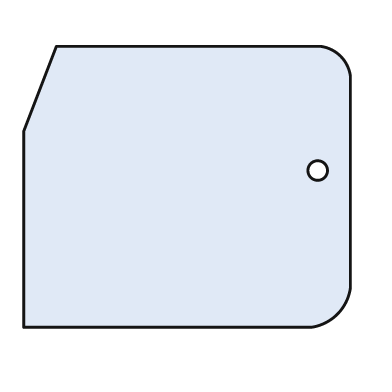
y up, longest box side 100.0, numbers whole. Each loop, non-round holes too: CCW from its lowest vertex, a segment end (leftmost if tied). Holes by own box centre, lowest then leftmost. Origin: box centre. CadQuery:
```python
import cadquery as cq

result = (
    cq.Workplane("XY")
    .moveTo(-50.0, -43.0)
    .lineTo(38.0, -43.0)
    .threePointArc((46.0, -39.0), (50.0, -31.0))
    .lineTo(50.0, 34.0)
    .threePointArc((47.0, 40.0), (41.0, 43.0))
    .lineTo(-40.0, 43.0)
    .lineTo(-50.0, 17.0)
    .close()
    .moveTo(40.0, 5.0)
    .circle(3.0)
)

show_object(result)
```